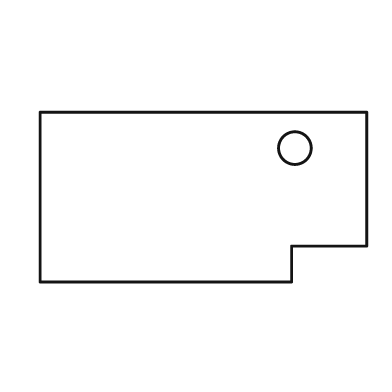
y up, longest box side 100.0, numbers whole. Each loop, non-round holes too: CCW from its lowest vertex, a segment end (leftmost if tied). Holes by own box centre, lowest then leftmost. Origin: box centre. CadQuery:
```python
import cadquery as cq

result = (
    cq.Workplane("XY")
    .moveTo(-50.0, -26.0)
    .lineTo(27.0, -26.0)
    .lineTo(27.0, -15.0)
    .lineTo(50.0, -15.0)
    .lineTo(50.0, 26.0)
    .lineTo(-50.0, 26.0)
    .close()
    .moveTo(28.0, 15.0)
    .circle(5.0)
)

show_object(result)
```